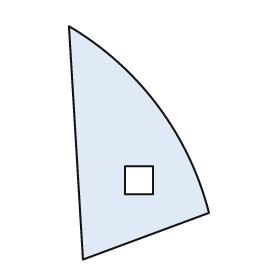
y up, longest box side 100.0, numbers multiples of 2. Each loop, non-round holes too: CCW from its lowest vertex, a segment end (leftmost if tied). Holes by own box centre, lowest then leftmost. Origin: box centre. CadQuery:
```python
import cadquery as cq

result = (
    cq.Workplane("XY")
    .moveTo(-24.0, -50.0)
    .lineTo(30.0, -30.0)
    .threePointArc((8.0, 16.0), (-30.0, 50.0))
    .close()
    .moveTo(-6.0, -22.0)
    .lineTo(6.0, -22.0)
    .lineTo(6.0, -10.0)
    .lineTo(-6.0, -10.0)
    .close()
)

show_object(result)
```